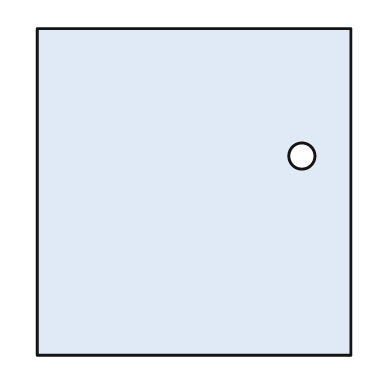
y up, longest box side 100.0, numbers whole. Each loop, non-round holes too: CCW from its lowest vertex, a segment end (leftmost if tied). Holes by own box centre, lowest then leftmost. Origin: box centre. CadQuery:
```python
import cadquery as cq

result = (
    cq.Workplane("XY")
    .moveTo(-48.0, -50.0)
    .lineTo(48.0, -50.0)
    .lineTo(48.0, 50.0)
    .lineTo(-48.0, 50.0)
    .close()
    .moveTo(33.0, 11.0)
    .circle(4.0)
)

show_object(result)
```